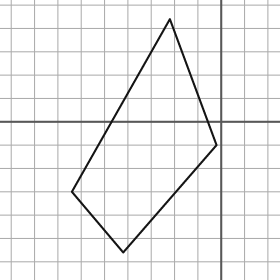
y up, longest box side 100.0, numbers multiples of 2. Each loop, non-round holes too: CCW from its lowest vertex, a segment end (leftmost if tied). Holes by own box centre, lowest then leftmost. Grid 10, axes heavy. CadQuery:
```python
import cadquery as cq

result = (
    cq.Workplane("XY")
    .moveTo(-42.0, -56.0)
    .lineTo(-2.0, -10.0)
    .lineTo(-22.0, 44.0)
    .lineTo(-64.0, -30.0)
    .close()
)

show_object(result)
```